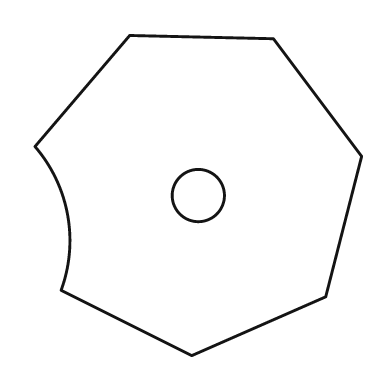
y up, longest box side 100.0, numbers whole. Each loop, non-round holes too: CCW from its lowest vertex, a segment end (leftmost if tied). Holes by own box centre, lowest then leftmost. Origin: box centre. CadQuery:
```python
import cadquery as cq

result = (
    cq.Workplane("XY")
    .moveTo(-2.0, -49.0)
    .lineTo(39.0, -31.0)
    .lineTo(50.0, 12.0)
    .lineTo(23.0, 48.0)
    .lineTo(-21.0, 49.0)
    .lineTo(-50.0, 15.0)
    .threePointArc((-40.0, -6.0), (-42.0, -29.0))
    .close()
    .moveTo(0.0, 0.0)
    .circle(8.0)
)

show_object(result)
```